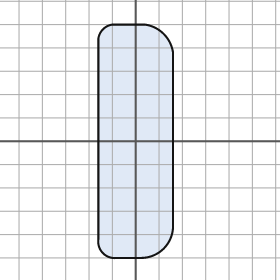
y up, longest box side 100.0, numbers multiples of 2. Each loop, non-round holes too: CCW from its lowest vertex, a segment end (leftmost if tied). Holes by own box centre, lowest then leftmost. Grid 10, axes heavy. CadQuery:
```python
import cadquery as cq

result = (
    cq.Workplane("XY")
    .moveTo(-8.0, -50.0)
    .lineTo(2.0, -50.0)
    .threePointArc((12.0, -46.0), (16.0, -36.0))
    .lineTo(16.0, 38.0)
    .threePointArc((12.0, 46.0), (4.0, 50.0))
    .lineTo(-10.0, 50.0)
    .threePointArc((-14.0, 48.0), (-16.0, 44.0))
    .lineTo(-16.0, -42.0)
    .threePointArc((-14.0, -48.0), (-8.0, -50.0))
    .close()
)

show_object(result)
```